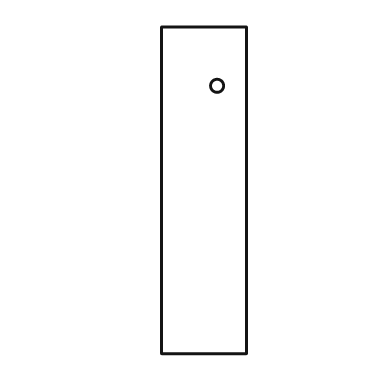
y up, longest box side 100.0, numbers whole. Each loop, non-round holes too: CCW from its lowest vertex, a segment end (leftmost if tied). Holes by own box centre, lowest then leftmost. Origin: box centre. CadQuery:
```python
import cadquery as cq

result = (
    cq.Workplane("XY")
    .moveTo(-13.0, -50.0)
    .lineTo(13.0, -50.0)
    .lineTo(13.0, 50.0)
    .lineTo(-13.0, 50.0)
    .close()
    .moveTo(4.0, 32.0)
    .circle(2.0)
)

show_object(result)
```